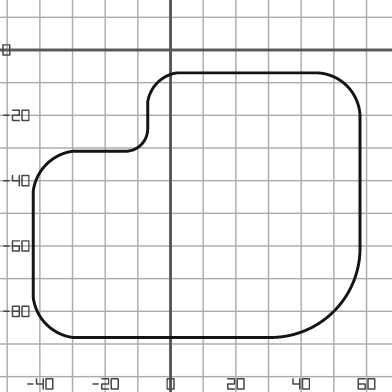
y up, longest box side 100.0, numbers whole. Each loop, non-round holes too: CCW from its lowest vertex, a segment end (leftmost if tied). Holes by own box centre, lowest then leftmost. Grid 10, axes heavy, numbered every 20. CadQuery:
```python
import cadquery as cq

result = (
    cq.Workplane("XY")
    .moveTo(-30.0, -88.0)
    .lineTo(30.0, -88.0)
    .threePointArc((50.0, -80.0), (58.0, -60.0))
    .lineTo(58.0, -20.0)
    .threePointArc((54.0, -11.0), (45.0, -7.0))
    .lineTo(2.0, -7.0)
    .threePointArc((-4.0, -10.0), (-7.0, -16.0))
    .lineTo(-7.0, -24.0)
    .threePointArc((-9.0, -29.0), (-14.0, -31.0))
    .lineTo(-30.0, -31.0)
    .threePointArc((-38.0, -35.0), (-42.0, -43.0))
    .lineTo(-42.0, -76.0)
    .threePointArc((-38.0, -84.0), (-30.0, -88.0))
    .close()
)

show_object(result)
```